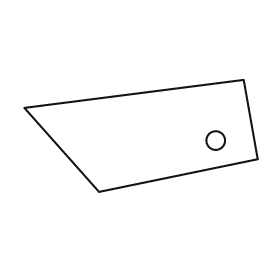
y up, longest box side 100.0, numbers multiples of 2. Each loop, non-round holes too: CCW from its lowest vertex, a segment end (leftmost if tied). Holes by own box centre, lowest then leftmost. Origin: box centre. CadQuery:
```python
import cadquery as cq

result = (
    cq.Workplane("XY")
    .moveTo(-18.0, -24.0)
    .lineTo(50.0, -10.0)
    .lineTo(44.0, 24.0)
    .lineTo(-50.0, 12.0)
    .close()
    .moveTo(32.0, -2.0)
    .circle(4.0)
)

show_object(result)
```